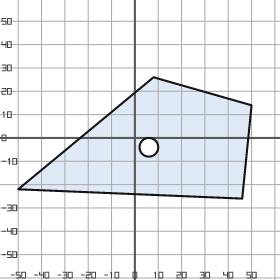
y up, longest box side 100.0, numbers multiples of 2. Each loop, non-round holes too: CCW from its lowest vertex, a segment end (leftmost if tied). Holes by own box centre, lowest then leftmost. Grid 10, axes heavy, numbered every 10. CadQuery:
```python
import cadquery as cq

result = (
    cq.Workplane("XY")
    .moveTo(46.0, -26.0)
    .lineTo(50.0, 14.0)
    .lineTo(8.0, 26.0)
    .lineTo(-50.0, -22.0)
    .close()
    .moveTo(6.0, -4.0)
    .circle(4.0)
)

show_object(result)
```